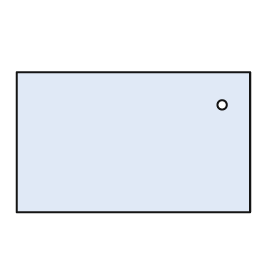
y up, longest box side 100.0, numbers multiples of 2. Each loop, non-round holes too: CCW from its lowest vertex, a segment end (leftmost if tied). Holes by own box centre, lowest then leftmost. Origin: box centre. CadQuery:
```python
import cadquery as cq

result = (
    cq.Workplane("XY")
    .moveTo(-50.0, -30.0)
    .lineTo(50.0, -30.0)
    .lineTo(50.0, 30.0)
    .lineTo(-50.0, 30.0)
    .close()
    .moveTo(38.0, 16.0)
    .circle(2.0)
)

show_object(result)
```